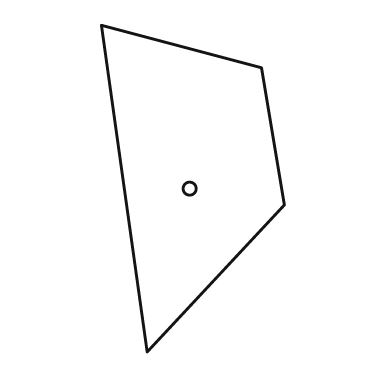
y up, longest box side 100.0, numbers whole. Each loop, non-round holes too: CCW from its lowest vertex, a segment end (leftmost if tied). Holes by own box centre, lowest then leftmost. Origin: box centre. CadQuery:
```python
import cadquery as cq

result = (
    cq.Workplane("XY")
    .moveTo(-14.0, -50.0)
    .lineTo(28.0, -5.0)
    .lineTo(21.0, 37.0)
    .lineTo(-28.0, 50.0)
    .close()
    .moveTo(-1.0, 0.0)
    .circle(2.0)
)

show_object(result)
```